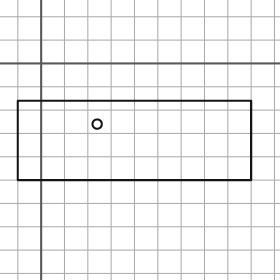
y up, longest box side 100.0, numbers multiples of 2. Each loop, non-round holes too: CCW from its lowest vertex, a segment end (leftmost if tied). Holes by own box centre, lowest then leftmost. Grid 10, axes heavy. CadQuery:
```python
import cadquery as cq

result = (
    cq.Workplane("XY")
    .moveTo(-10.0, -50.0)
    .lineTo(90.0, -50.0)
    .lineTo(90.0, -16.0)
    .lineTo(-10.0, -16.0)
    .close()
    .moveTo(24.0, -26.0)
    .circle(2.0)
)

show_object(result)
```